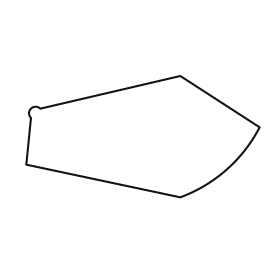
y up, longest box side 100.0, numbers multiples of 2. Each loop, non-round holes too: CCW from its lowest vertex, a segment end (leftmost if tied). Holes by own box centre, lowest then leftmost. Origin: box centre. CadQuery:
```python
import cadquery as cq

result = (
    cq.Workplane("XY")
    .moveTo(16.0, -26.0)
    .threePointArc((36.0, -14.0), (50.0, 4.0))
    .lineTo(16.0, 26.0)
    .lineTo(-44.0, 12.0)
    .threePointArc((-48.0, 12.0), (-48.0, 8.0))
    .lineTo(-50.0, -12.0)
    .close()
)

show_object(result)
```